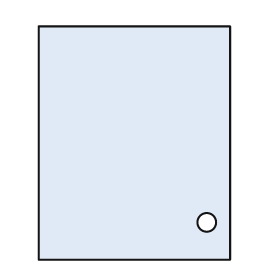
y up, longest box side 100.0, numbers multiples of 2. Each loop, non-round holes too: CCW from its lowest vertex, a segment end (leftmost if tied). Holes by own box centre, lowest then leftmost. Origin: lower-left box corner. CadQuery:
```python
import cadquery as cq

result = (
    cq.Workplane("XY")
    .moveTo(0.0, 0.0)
    .lineTo(82.0, 0.0)
    .lineTo(82.0, 100.0)
    .lineTo(0.0, 100.0)
    .close()
    .moveTo(72.0, 16.0)
    .circle(4.0)
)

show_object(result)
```